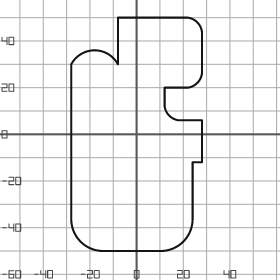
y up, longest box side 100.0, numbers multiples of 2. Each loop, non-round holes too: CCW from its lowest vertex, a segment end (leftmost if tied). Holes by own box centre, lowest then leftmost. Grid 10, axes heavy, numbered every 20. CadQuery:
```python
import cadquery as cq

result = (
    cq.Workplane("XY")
    .moveTo(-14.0, -50.0)
    .lineTo(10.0, -50.0)
    .threePointArc((20.0, -46.0), (24.0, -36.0))
    .lineTo(24.0, -12.0)
    .lineTo(28.0, -12.0)
    .lineTo(28.0, 6.0)
    .lineTo(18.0, 6.0)
    .threePointArc((14.0, 8.0), (12.0, 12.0))
    .lineTo(12.0, 20.0)
    .lineTo(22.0, 20.0)
    .threePointArc((26.0, 22.0), (28.0, 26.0))
    .lineTo(28.0, 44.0)
    .threePointArc((26.0, 48.0), (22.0, 50.0))
    .lineTo(-8.0, 50.0)
    .lineTo(-8.0, 30.0)
    .threePointArc((-18.0, 36.0), (-28.0, 30.0))
    .lineTo(-28.0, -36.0)
    .threePointArc((-24.0, -46.0), (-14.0, -50.0))
    .close()
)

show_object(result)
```